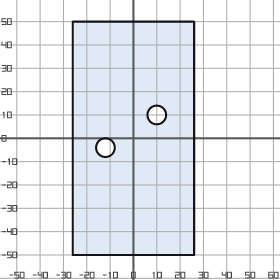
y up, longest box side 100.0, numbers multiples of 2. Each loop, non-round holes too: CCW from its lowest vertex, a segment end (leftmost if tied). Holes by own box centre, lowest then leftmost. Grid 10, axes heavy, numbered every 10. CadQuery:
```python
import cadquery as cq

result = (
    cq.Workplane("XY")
    .moveTo(-26.0, -50.0)
    .lineTo(26.0, -50.0)
    .lineTo(26.0, 50.0)
    .lineTo(-26.0, 50.0)
    .close()
    .moveTo(-12.0, -4.0)
    .circle(4.0)
    .moveTo(10.0, 10.0)
    .circle(4.0)
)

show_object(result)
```